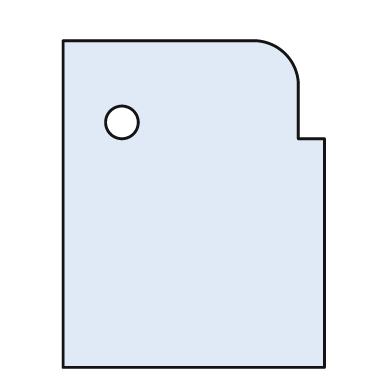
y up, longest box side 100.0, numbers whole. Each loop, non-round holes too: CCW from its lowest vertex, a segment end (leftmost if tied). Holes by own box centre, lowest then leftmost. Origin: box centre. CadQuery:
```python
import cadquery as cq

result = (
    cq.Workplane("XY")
    .moveTo(-40.0, -50.0)
    .lineTo(40.0, -50.0)
    .lineTo(40.0, 20.0)
    .lineTo(32.0, 20.0)
    .lineTo(32.0, 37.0)
    .threePointArc((28.0, 46.0), (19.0, 50.0))
    .lineTo(-40.0, 50.0)
    .close()
    .moveTo(-22.0, 25.0)
    .circle(5.0)
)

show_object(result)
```